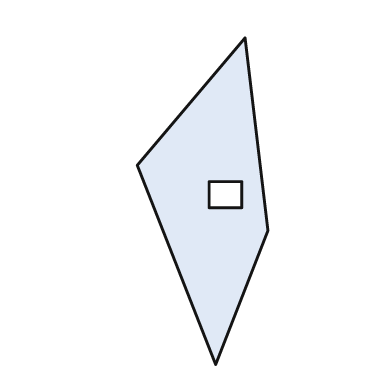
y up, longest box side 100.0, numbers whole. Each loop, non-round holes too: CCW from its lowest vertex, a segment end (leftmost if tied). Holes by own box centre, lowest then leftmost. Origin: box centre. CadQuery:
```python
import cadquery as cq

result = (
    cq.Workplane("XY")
    .moveTo(4.0, -50.0)
    .lineTo(20.0, -9.0)
    .lineTo(13.0, 50.0)
    .lineTo(-20.0, 11.0)
    .close()
    .moveTo(2.0, -2.0)
    .lineTo(12.0, -2.0)
    .lineTo(12.0, 6.0)
    .lineTo(2.0, 6.0)
    .close()
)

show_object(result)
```